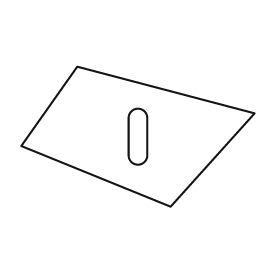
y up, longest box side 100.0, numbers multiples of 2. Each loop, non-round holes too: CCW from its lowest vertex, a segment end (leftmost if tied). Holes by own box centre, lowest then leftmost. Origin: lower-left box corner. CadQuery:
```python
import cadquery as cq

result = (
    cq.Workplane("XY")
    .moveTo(64.0, 0.0)
    .lineTo(100.0, 40.0)
    .lineTo(24.0, 60.0)
    .lineTo(0.0, 26.0)
    .close()
    .moveTo(46.0, 22.0)
    .threePointArc((50.0, 18.0), (54.0, 22.0))
    .lineTo(54.0, 38.0)
    .threePointArc((50.0, 42.0), (46.0, 38.0))
    .close()
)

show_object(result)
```